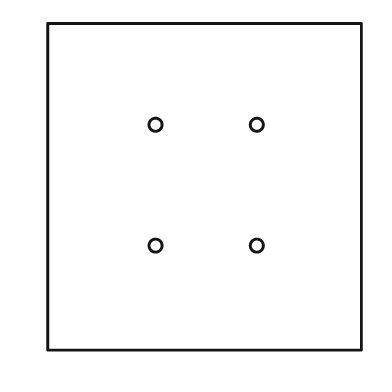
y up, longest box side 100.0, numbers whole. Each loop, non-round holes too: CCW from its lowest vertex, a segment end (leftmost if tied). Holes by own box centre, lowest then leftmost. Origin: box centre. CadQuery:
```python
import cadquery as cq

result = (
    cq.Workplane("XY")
    .moveTo(-48.0, -50.0)
    .lineTo(48.0, -50.0)
    .lineTo(48.0, 50.0)
    .lineTo(-48.0, 50.0)
    .close()
    .moveTo(-15.0, -18.0)
    .circle(2.0)
    .moveTo(16.0, -18.0)
    .circle(2.0)
    .moveTo(-15.0, 19.0)
    .circle(2.0)
    .moveTo(16.0, 19.0)
    .circle(2.0)
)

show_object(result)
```